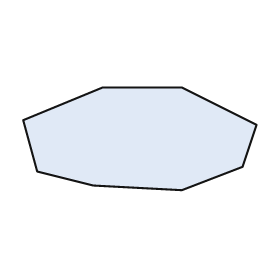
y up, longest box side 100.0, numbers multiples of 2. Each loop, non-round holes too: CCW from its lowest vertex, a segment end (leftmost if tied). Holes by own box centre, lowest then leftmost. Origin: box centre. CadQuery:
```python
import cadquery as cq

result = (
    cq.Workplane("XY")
    .moveTo(18.0, -22.0)
    .lineTo(44.0, -12.0)
    .lineTo(50.0, 6.0)
    .lineTo(18.0, 22.0)
    .lineTo(-16.0, 22.0)
    .lineTo(-50.0, 8.0)
    .lineTo(-44.0, -14.0)
    .lineTo(-20.0, -20.0)
    .close()
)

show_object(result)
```